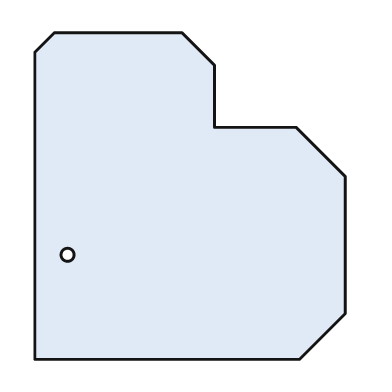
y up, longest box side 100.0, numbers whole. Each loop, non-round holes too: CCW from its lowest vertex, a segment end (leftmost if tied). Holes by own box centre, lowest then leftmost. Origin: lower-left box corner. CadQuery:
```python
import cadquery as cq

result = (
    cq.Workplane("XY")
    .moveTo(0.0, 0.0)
    .lineTo(81.0, 0.0)
    .lineTo(95.0, 14.0)
    .lineTo(95.0, 56.0)
    .lineTo(80.0, 71.0)
    .lineTo(55.0, 71.0)
    .lineTo(55.0, 90.0)
    .lineTo(45.0, 100.0)
    .lineTo(6.0, 100.0)
    .lineTo(0.0, 94.0)
    .close()
    .moveTo(10.0, 32.0)
    .circle(2.0)
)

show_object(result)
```